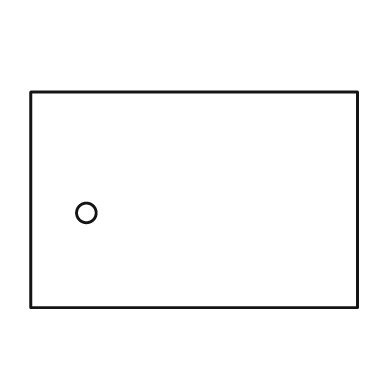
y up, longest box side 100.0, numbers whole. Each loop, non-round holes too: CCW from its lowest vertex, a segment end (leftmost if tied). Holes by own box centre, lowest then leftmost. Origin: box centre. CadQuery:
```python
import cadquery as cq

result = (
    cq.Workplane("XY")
    .moveTo(-50.0, -33.0)
    .lineTo(50.0, -33.0)
    .lineTo(50.0, 33.0)
    .lineTo(-50.0, 33.0)
    .close()
    .moveTo(-33.0, -4.0)
    .circle(3.0)
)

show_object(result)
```